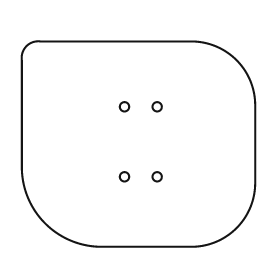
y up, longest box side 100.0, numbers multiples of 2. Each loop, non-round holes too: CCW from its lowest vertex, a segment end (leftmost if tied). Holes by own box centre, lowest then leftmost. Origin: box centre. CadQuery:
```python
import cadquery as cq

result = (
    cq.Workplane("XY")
    .moveTo(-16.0, -44.0)
    .lineTo(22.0, -44.0)
    .threePointArc((42.0, -36.0), (50.0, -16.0))
    .lineTo(50.0, 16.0)
    .threePointArc((42.0, 36.0), (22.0, 44.0))
    .lineTo(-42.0, 44.0)
    .threePointArc((-48.0, 42.0), (-50.0, 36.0))
    .lineTo(-50.0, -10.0)
    .threePointArc((-40.0, -34.0), (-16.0, -44.0))
    .close()
    .moveTo(-6.0, -14.0)
    .circle(2.0)
    .moveTo(8.0, -14.0)
    .circle(2.0)
    .moveTo(-6.0, 16.0)
    .circle(2.0)
    .moveTo(8.0, 16.0)
    .circle(2.0)
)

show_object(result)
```